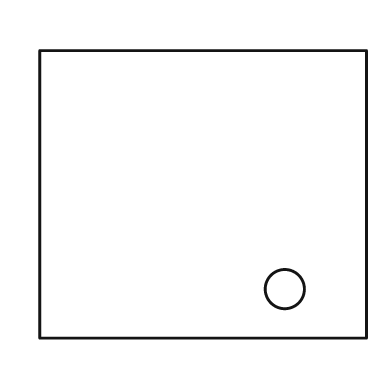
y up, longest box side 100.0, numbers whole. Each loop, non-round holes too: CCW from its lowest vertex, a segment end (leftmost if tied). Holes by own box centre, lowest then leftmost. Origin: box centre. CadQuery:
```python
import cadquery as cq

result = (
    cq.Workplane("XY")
    .moveTo(-50.0, -44.0)
    .lineTo(50.0, -44.0)
    .lineTo(50.0, 44.0)
    .lineTo(-50.0, 44.0)
    .close()
    .moveTo(25.0, -29.0)
    .circle(6.0)
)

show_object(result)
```